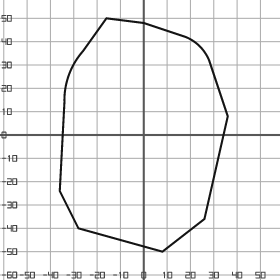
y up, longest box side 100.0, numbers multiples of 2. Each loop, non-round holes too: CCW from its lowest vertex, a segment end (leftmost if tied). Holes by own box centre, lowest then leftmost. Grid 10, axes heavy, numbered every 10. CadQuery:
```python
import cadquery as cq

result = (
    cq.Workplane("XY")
    .moveTo(8.0, -50.0)
    .lineTo(26.0, -36.0)
    .lineTo(36.0, 8.0)
    .lineTo(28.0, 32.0)
    .threePointArc((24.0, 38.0), (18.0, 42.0))
    .lineTo(0.0, 48.0)
    .lineTo(-16.0, 50.0)
    .lineTo(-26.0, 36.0)
    .threePointArc((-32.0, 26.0), (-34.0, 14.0))
    .lineTo(-36.0, -24.0)
    .lineTo(-28.0, -40.0)
    .close()
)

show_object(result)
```